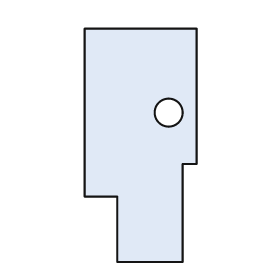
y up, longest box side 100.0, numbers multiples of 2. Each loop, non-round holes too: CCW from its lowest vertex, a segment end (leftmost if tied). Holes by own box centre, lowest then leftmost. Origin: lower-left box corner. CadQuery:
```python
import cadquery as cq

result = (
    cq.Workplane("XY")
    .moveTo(14.0, 0.0)
    .lineTo(42.0, 0.0)
    .lineTo(42.0, 42.0)
    .lineTo(48.0, 42.0)
    .lineTo(48.0, 100.0)
    .lineTo(0.0, 100.0)
    .lineTo(0.0, 28.0)
    .lineTo(14.0, 28.0)
    .close()
    .moveTo(36.0, 64.0)
    .circle(6.0)
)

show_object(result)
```